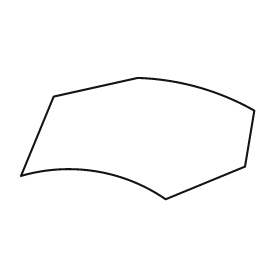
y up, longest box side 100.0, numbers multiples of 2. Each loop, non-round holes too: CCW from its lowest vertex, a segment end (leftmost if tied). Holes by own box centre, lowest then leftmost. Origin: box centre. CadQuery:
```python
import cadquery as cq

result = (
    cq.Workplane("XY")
    .moveTo(12.0, -26.0)
    .lineTo(46.0, -12.0)
    .lineTo(50.0, 12.0)
    .threePointArc((26.0, 22.0), (0.0, 26.0))
    .lineTo(-36.0, 18.0)
    .lineTo(-50.0, -16.0)
    .threePointArc((-18.0, -14.0), (12.0, -26.0))
    .close()
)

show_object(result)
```